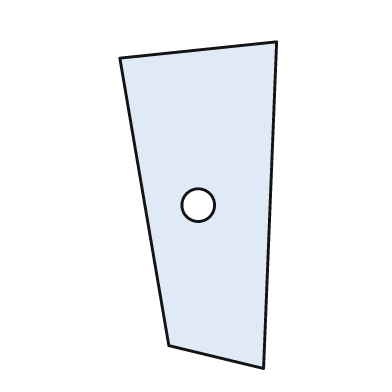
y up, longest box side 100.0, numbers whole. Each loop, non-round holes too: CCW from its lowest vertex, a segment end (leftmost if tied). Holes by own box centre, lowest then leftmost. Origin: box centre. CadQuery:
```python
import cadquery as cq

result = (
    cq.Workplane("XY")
    .moveTo(20.0, -50.0)
    .lineTo(24.0, 50.0)
    .lineTo(-24.0, 45.0)
    .lineTo(-9.0, -43.0)
    .close()
    .moveTo(0.0, 0.0)
    .circle(5.0)
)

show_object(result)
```